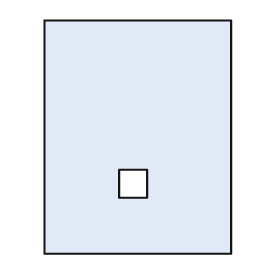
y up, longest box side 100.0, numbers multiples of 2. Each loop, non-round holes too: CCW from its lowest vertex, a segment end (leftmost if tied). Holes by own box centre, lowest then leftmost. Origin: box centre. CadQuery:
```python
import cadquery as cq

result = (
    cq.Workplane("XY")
    .moveTo(-40.0, -50.0)
    .lineTo(40.0, -50.0)
    .lineTo(40.0, 50.0)
    .lineTo(-40.0, 50.0)
    .close()
    .moveTo(-8.0, -26.0)
    .lineTo(4.0, -26.0)
    .lineTo(4.0, -14.0)
    .lineTo(-8.0, -14.0)
    .close()
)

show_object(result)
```